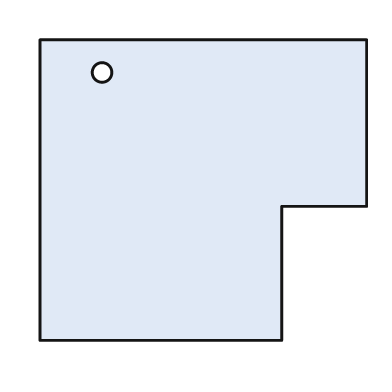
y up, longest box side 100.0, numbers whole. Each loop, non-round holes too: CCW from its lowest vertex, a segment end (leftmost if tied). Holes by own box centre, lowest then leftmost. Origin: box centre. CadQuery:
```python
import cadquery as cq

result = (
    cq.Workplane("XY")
    .moveTo(-50.0, -46.0)
    .lineTo(24.0, -46.0)
    .lineTo(24.0, -5.0)
    .lineTo(50.0, -5.0)
    .lineTo(50.0, 46.0)
    .lineTo(-50.0, 46.0)
    .close()
    .moveTo(-31.0, 36.0)
    .circle(3.0)
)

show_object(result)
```